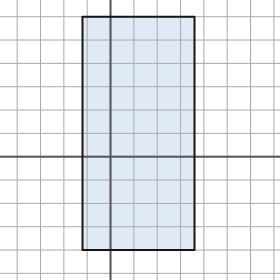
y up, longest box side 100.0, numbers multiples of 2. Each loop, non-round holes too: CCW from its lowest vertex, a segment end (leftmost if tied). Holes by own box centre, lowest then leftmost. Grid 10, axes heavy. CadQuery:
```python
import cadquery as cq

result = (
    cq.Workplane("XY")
    .moveTo(-12.0, -40.0)
    .lineTo(36.0, -40.0)
    .lineTo(36.0, 60.0)
    .lineTo(-12.0, 60.0)
    .close()
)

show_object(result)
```